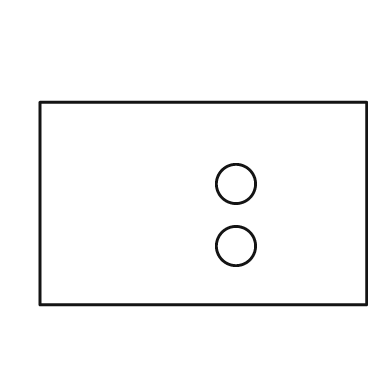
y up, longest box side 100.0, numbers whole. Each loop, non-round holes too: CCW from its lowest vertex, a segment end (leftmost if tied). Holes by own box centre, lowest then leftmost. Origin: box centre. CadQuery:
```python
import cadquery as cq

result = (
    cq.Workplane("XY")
    .moveTo(-50.0, -31.0)
    .lineTo(50.0, -31.0)
    .lineTo(50.0, 31.0)
    .lineTo(-50.0, 31.0)
    .close()
    .moveTo(10.0, -13.0)
    .circle(6.0)
    .moveTo(10.0, 6.0)
    .circle(6.0)
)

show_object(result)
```